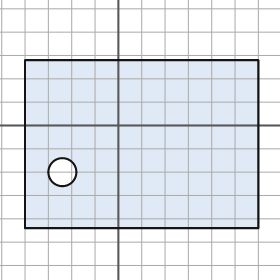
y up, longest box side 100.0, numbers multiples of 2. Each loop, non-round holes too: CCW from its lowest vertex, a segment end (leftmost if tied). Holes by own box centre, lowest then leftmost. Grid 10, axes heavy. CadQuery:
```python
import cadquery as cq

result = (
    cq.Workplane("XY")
    .moveTo(-40.0, -44.0)
    .lineTo(60.0, -44.0)
    .lineTo(60.0, 28.0)
    .lineTo(-40.0, 28.0)
    .close()
    .moveTo(-24.0, -20.0)
    .circle(6.0)
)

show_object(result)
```